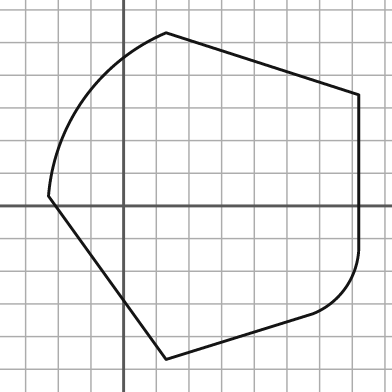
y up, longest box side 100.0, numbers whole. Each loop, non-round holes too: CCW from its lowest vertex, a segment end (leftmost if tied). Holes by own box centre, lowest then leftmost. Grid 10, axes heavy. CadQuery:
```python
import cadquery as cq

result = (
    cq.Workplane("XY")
    .moveTo(13.0, -47.0)
    .lineTo(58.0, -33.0)
    .threePointArc((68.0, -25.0), (72.0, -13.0))
    .lineTo(72.0, 34.0)
    .lineTo(13.0, 53.0)
    .threePointArc((-12.0, 33.0), (-23.0, 3.0))
    .close()
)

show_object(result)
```